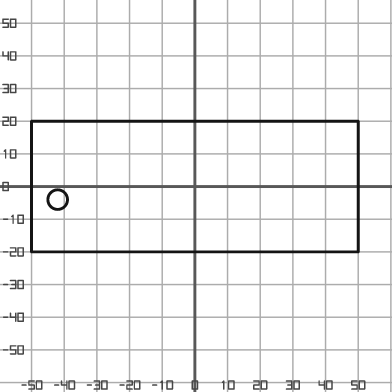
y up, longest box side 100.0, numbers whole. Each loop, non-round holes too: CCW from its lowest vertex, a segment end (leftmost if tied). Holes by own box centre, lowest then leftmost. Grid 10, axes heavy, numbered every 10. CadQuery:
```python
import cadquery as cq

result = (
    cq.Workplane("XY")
    .moveTo(-50.0, -20.0)
    .lineTo(50.0, -20.0)
    .lineTo(50.0, 20.0)
    .lineTo(-50.0, 20.0)
    .close()
    .moveTo(-42.0, -4.0)
    .circle(3.0)
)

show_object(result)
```